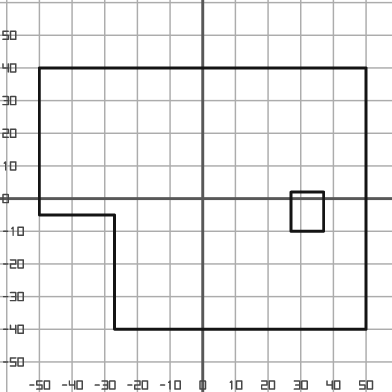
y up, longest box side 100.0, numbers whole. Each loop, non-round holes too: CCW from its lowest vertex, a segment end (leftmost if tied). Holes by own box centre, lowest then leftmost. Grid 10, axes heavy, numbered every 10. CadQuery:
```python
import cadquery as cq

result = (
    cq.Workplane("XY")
    .moveTo(-27.0, -40.0)
    .lineTo(50.0, -40.0)
    .lineTo(50.0, 40.0)
    .lineTo(-50.0, 40.0)
    .lineTo(-50.0, -5.0)
    .lineTo(-27.0, -5.0)
    .close()
    .moveTo(27.0, -10.0)
    .lineTo(37.0, -10.0)
    .lineTo(37.0, 2.0)
    .lineTo(27.0, 2.0)
    .close()
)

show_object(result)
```